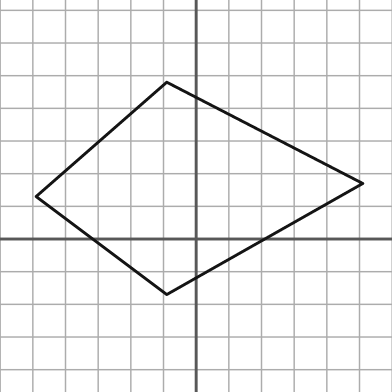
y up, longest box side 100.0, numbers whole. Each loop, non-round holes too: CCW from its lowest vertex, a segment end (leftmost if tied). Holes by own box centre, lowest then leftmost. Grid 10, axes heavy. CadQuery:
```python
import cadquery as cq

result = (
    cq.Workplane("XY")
    .moveTo(-9.0, -17.0)
    .lineTo(51.0, 17.0)
    .lineTo(-9.0, 48.0)
    .lineTo(-49.0, 13.0)
    .close()
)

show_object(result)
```